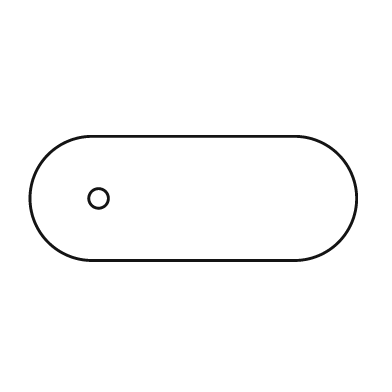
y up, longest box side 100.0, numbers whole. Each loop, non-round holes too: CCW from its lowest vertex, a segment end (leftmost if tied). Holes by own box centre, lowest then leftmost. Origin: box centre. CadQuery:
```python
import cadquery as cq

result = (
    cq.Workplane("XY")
    .moveTo(-31.0, -19.0)
    .lineTo(31.0, -19.0)
    .threePointArc((50.0, 0.0), (31.0, 19.0))
    .lineTo(-31.0, 19.0)
    .threePointArc((-50.0, 0.0), (-31.0, -19.0))
    .close()
    .moveTo(-29.0, 0.0)
    .circle(3.0)
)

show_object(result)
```